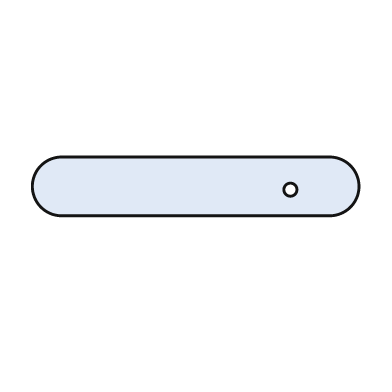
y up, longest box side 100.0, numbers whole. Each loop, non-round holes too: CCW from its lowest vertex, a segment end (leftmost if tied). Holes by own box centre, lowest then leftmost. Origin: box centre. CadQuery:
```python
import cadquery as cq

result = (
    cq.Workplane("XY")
    .moveTo(-41.0, -9.0)
    .lineTo(41.0, -9.0)
    .threePointArc((50.0, 0.0), (41.0, 9.0))
    .lineTo(-41.0, 9.0)
    .threePointArc((-50.0, 0.0), (-41.0, -9.0))
    .close()
    .moveTo(29.0, -1.0)
    .circle(2.0)
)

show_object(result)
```